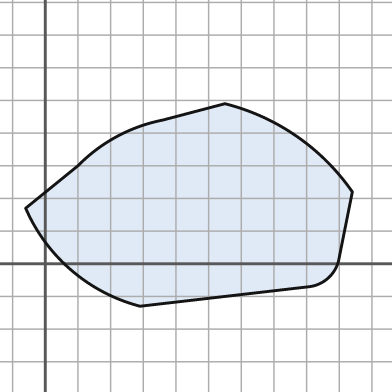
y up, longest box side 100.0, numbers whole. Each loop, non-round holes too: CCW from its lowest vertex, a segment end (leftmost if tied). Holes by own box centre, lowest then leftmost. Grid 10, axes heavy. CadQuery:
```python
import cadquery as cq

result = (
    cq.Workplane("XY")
    .moveTo(29.0, -13.0)
    .lineTo(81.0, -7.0)
    .threePointArc((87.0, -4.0), (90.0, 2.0))
    .lineTo(94.0, 22.0)
    .threePointArc((77.0, 39.0), (55.0, 49.0))
    .lineTo(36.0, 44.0)
    .threePointArc((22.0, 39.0), (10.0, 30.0))
    .lineTo(-6.0, 17.0)
    .threePointArc((8.0, -2.0), (29.0, -13.0))
    .close()
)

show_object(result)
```